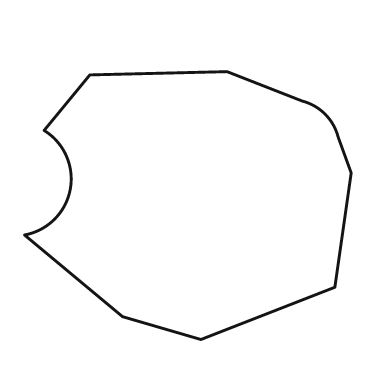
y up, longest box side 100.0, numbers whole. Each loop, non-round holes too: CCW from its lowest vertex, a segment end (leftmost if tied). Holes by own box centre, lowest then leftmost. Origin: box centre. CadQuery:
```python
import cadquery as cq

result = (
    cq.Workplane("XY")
    .moveTo(4.0, -41.0)
    .lineTo(45.0, -25.0)
    .lineTo(50.0, 10.0)
    .lineTo(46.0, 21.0)
    .threePointArc((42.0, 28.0), (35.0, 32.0))
    .lineTo(12.0, 41.0)
    .lineTo(-30.0, 40.0)
    .lineTo(-44.0, 23.0)
    .threePointArc((-36.0, 5.0), (-50.0, -9.0))
    .lineTo(-20.0, -34.0)
    .close()
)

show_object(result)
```